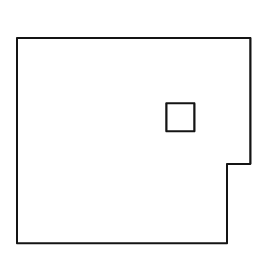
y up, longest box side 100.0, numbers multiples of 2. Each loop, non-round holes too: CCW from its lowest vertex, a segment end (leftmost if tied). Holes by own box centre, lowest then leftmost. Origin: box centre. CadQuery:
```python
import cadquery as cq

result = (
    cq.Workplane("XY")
    .moveTo(-50.0, -44.0)
    .lineTo(40.0, -44.0)
    .lineTo(40.0, -10.0)
    .lineTo(50.0, -10.0)
    .lineTo(50.0, 44.0)
    .lineTo(-50.0, 44.0)
    .close()
    .moveTo(14.0, 4.0)
    .lineTo(26.0, 4.0)
    .lineTo(26.0, 16.0)
    .lineTo(14.0, 16.0)
    .close()
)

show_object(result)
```